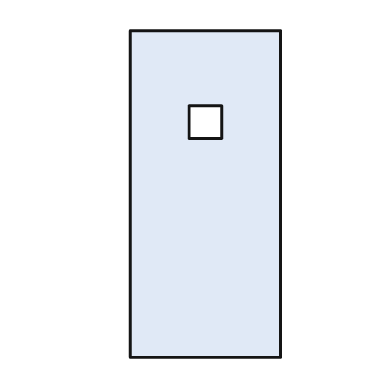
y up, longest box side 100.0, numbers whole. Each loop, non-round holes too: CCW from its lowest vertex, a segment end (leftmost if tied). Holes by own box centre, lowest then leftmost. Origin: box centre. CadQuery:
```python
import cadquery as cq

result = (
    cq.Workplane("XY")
    .moveTo(-23.0, -50.0)
    .lineTo(23.0, -50.0)
    .lineTo(23.0, 50.0)
    .lineTo(-23.0, 50.0)
    .close()
    .moveTo(-5.0, 17.0)
    .lineTo(5.0, 17.0)
    .lineTo(5.0, 27.0)
    .lineTo(-5.0, 27.0)
    .close()
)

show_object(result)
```